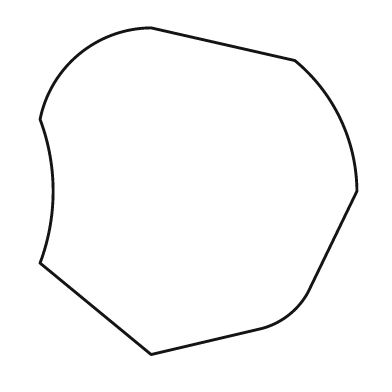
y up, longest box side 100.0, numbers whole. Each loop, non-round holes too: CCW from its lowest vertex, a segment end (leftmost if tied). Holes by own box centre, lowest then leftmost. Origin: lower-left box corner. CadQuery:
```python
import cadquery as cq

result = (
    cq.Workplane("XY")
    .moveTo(34.0, 0.0)
    .lineTo(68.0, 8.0)
    .threePointArc((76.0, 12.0), (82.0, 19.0))
    .lineTo(97.0, 50.0)
    .threePointArc((92.0, 72.0), (78.0, 90.0))
    .lineTo(34.0, 100.0)
    .threePointArc((12.0, 92.0), (0.0, 72.0))
    .threePointArc((4.0, 50.0), (0.0, 28.0))
    .close()
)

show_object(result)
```